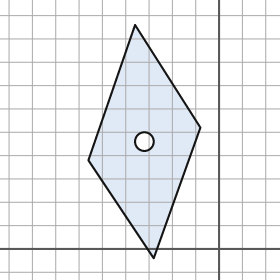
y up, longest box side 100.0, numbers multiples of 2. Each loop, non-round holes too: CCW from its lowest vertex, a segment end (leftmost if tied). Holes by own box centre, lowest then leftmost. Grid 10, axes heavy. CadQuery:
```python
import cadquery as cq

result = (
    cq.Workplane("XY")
    .moveTo(-28.0, -4.0)
    .lineTo(-8.0, 52.0)
    .lineTo(-36.0, 96.0)
    .lineTo(-56.0, 38.0)
    .close()
    .moveTo(-32.0, 46.0)
    .circle(4.0)
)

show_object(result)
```